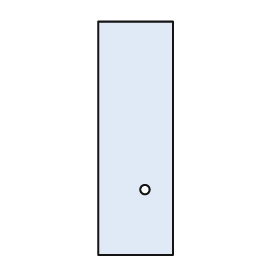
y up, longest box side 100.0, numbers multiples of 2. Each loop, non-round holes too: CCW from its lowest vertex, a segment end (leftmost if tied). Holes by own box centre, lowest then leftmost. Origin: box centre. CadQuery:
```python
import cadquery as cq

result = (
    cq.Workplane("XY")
    .moveTo(-16.0, -50.0)
    .lineTo(16.0, -50.0)
    .lineTo(16.0, 50.0)
    .lineTo(-16.0, 50.0)
    .close()
    .moveTo(4.0, -22.0)
    .circle(2.0)
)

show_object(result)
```